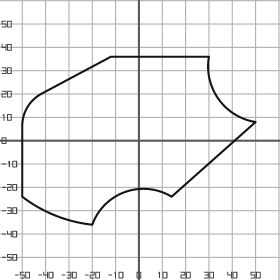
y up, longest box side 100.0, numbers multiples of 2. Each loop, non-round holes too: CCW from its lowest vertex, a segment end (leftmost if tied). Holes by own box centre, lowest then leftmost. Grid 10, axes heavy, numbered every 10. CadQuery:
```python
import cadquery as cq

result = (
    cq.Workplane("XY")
    .moveTo(-20.0, -36.0)
    .threePointArc((-6.0, -22.0), (14.0, -24.0))
    .lineTo(50.0, 8.0)
    .threePointArc((34.0, 18.0), (30.0, 36.0))
    .lineTo(-12.0, 36.0)
    .lineTo(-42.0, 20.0)
    .threePointArc((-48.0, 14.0), (-50.0, 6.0))
    .lineTo(-50.0, -24.0)
    .threePointArc((-36.0, -32.0), (-20.0, -36.0))
    .close()
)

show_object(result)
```